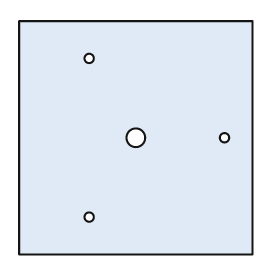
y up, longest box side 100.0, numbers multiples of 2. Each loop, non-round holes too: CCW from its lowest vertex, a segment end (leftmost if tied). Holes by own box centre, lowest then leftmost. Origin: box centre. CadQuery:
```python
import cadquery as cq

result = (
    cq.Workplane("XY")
    .moveTo(-50.0, -50.0)
    .lineTo(50.0, -50.0)
    .lineTo(50.0, 50.0)
    .lineTo(-50.0, 50.0)
    .close()
    .moveTo(-20.0, -34.0)
    .circle(2.0)
    .moveTo(0.0, 0.0)
    .circle(4.0)
    .moveTo(38.0, 0.0)
    .circle(2.0)
    .moveTo(-20.0, 34.0)
    .circle(2.0)
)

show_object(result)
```